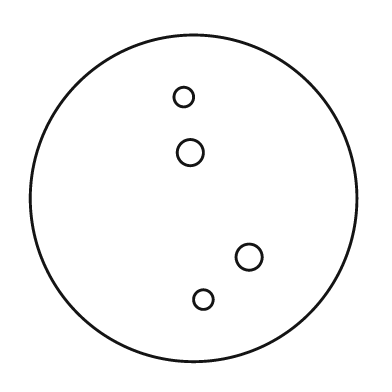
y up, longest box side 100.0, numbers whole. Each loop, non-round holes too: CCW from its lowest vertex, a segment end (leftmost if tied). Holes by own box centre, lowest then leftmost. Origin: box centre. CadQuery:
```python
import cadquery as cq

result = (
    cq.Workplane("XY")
    .moveTo(0.0, 0.0)
    .circle(50.0)
    .moveTo(3.0, -31.0)
    .circle(3.0)
    .moveTo(17.0, -18.0)
    .circle(4.0)
    .moveTo(-1.0, 14.0)
    .circle(4.0)
    .moveTo(-3.0, 31.0)
    .circle(3.0)
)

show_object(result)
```